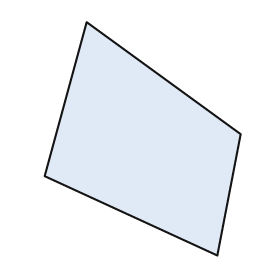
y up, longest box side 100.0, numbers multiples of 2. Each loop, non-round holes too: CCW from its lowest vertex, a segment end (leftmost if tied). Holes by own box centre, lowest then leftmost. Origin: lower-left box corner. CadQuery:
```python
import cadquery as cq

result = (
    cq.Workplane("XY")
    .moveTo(74.0, 0.0)
    .lineTo(84.0, 52.0)
    .lineTo(18.0, 100.0)
    .lineTo(0.0, 34.0)
    .close()
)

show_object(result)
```